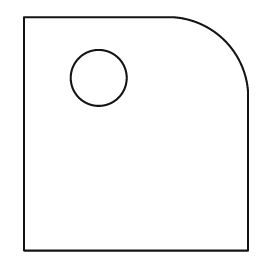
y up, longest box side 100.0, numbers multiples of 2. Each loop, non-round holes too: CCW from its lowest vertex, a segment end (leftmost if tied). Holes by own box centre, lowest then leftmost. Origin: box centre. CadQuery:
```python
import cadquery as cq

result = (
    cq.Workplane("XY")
    .moveTo(-48.0, -50.0)
    .lineTo(48.0, -50.0)
    .lineTo(48.0, 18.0)
    .threePointArc((38.0, 40.0), (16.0, 50.0))
    .lineTo(-48.0, 50.0)
    .close()
    .moveTo(-16.0, 24.0)
    .circle(12.0)
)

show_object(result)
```